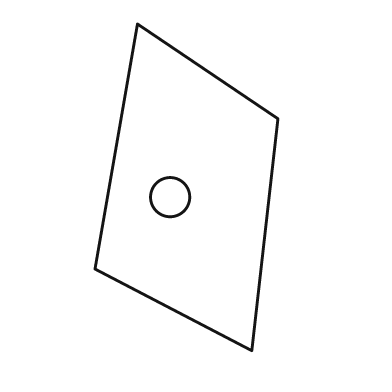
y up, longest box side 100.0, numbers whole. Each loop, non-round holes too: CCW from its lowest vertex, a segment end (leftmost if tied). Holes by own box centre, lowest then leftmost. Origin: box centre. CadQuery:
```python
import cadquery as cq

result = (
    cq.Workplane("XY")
    .moveTo(20.0, -50.0)
    .lineTo(28.0, 21.0)
    .lineTo(-15.0, 50.0)
    .lineTo(-28.0, -25.0)
    .close()
    .moveTo(-5.0, -3.0)
    .circle(6.0)
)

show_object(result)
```